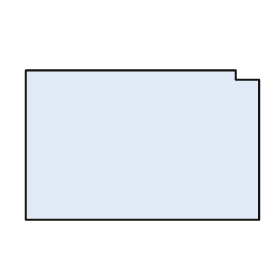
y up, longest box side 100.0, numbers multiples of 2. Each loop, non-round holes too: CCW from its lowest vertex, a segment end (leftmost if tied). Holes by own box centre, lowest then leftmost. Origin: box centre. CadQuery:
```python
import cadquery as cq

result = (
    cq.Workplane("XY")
    .moveTo(-50.0, -32.0)
    .lineTo(50.0, -32.0)
    .lineTo(50.0, 28.0)
    .lineTo(40.0, 28.0)
    .lineTo(40.0, 32.0)
    .lineTo(-50.0, 32.0)
    .close()
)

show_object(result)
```